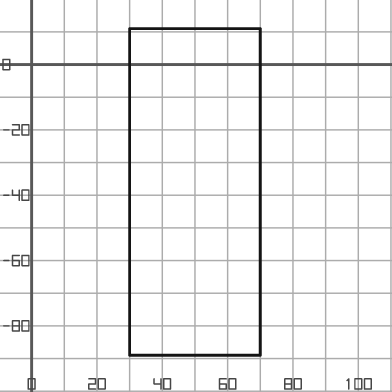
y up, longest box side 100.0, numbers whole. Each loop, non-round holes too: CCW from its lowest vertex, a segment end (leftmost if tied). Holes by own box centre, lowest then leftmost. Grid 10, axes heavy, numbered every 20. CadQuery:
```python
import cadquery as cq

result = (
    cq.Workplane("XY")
    .moveTo(30.0, -89.0)
    .lineTo(70.0, -89.0)
    .lineTo(70.0, 11.0)
    .lineTo(30.0, 11.0)
    .close()
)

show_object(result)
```